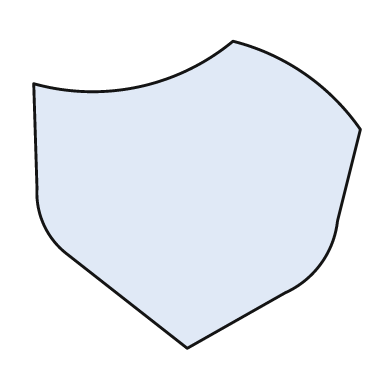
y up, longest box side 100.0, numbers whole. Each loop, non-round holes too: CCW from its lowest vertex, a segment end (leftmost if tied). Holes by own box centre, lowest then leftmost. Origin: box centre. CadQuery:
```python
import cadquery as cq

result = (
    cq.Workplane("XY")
    .moveTo(-3.0, -47.0)
    .lineTo(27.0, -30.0)
    .threePointArc((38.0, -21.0), (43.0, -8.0))
    .lineTo(50.0, 20.0)
    .threePointArc((33.0, 37.0), (11.0, 47.0))
    .threePointArc((-18.0, 33.0), (-50.0, 34.0))
    .lineTo(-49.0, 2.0)
    .threePointArc((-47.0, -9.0), (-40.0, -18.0))
    .close()
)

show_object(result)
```